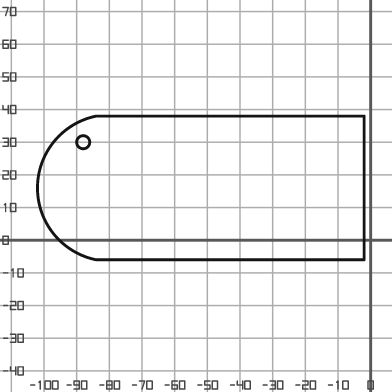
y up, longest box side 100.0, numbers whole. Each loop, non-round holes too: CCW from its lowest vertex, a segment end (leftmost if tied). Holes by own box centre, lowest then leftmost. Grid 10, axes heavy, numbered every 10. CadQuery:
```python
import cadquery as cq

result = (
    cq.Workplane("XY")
    .moveTo(-84.0, -6.0)
    .lineTo(-2.0, -6.0)
    .lineTo(-2.0, 38.0)
    .lineTo(-84.0, 38.0)
    .threePointArc((-102.0, 16.0), (-84.0, -6.0))
    .close()
    .moveTo(-88.0, 30.0)
    .circle(2.0)
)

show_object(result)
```